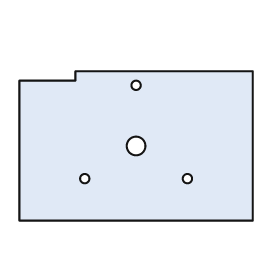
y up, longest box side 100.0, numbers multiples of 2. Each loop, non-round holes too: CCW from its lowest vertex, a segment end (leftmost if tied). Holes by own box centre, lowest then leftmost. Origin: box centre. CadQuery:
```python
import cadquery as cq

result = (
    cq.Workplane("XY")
    .moveTo(-50.0, -32.0)
    .lineTo(50.0, -32.0)
    .lineTo(50.0, 32.0)
    .lineTo(-26.0, 32.0)
    .lineTo(-26.0, 28.0)
    .lineTo(-50.0, 28.0)
    .close()
    .moveTo(-22.0, -14.0)
    .circle(2.0)
    .moveTo(22.0, -14.0)
    .circle(2.0)
    .moveTo(0.0, 0.0)
    .circle(4.0)
    .moveTo(0.0, 26.0)
    .circle(2.0)
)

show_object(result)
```